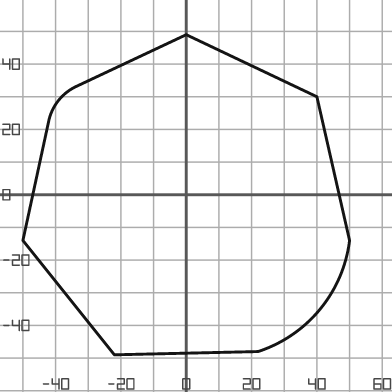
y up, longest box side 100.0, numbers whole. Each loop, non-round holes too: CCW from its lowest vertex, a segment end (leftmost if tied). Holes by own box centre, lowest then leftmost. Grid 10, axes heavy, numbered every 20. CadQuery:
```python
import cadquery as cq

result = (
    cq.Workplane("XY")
    .moveTo(-22.0, -49.0)
    .lineTo(22.0, -48.0)
    .threePointArc((41.0, -35.0), (50.0, -14.0))
    .lineTo(40.0, 30.0)
    .lineTo(0.0, 49.0)
    .lineTo(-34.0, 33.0)
    .threePointArc((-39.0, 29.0), (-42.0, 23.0))
    .lineTo(-50.0, -14.0)
    .close()
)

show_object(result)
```